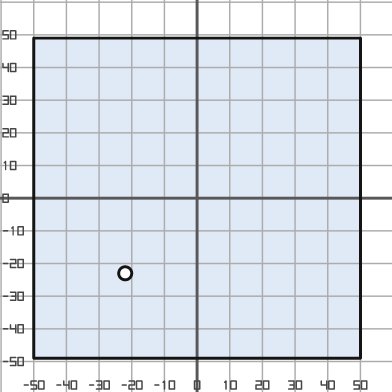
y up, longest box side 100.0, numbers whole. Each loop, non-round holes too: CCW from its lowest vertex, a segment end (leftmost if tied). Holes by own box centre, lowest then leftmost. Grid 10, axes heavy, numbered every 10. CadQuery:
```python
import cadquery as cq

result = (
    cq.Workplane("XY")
    .moveTo(-50.0, -49.0)
    .lineTo(50.0, -49.0)
    .lineTo(50.0, 49.0)
    .lineTo(-50.0, 49.0)
    .close()
    .moveTo(-22.0, -23.0)
    .circle(2.0)
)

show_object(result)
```